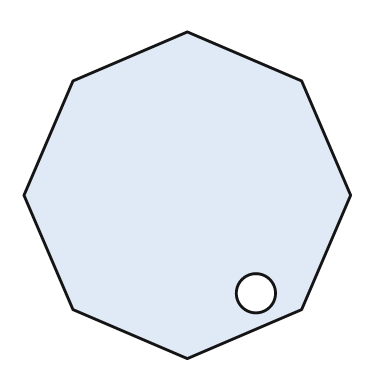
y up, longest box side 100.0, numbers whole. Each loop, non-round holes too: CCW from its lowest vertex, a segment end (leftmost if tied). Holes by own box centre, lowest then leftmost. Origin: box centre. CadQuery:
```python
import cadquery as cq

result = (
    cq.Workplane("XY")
    .moveTo(0.0, -50.0)
    .lineTo(35.0, -35.0)
    .lineTo(50.0, 0.0)
    .lineTo(35.0, 35.0)
    .lineTo(0.0, 50.0)
    .lineTo(-35.0, 35.0)
    .lineTo(-50.0, 0.0)
    .lineTo(-35.0, -35.0)
    .close()
    .moveTo(21.0, -30.0)
    .circle(6.0)
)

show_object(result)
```